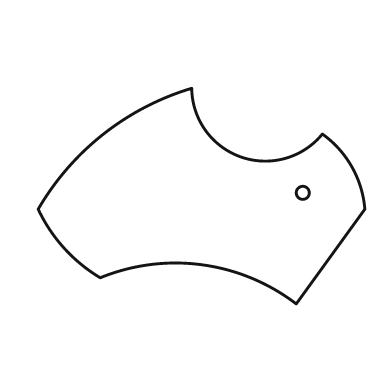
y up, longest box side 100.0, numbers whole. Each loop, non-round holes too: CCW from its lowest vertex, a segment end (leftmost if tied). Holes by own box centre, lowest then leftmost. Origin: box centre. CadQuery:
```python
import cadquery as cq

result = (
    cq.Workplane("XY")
    .moveTo(29.0, -33.0)
    .lineTo(50.0, -4.0)
    .threePointArc((46.0, 9.0), (37.0, 19.0))
    .threePointArc((12.0, 12.0), (-3.0, 33.0))
    .threePointArc((-30.0, 19.0), (-50.0, -4.0))
    .threePointArc((-42.0, -16.0), (-31.0, -25.0))
    .threePointArc((0.0, -21.0), (29.0, -33.0))
    .close()
    .moveTo(31.0, 1.0)
    .circle(2.0)
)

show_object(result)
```